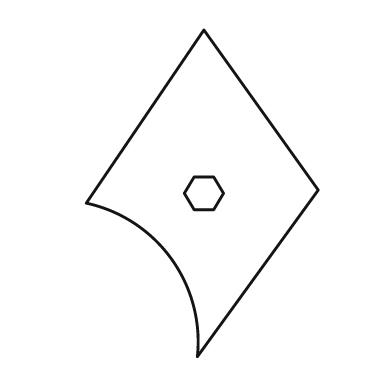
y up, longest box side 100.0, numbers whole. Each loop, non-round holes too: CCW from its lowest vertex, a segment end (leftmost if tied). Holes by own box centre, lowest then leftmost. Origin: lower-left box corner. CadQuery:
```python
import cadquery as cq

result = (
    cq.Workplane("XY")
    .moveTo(34.0, 0.0)
    .lineTo(71.0, 51.0)
    .lineTo(36.0, 100.0)
    .lineTo(0.0, 47.0)
    .threePointArc((26.0, 30.0), (34.0, 0.0))
    .close()
    .moveTo(33.0, 45.0)
    .lineTo(39.0, 45.0)
    .lineTo(42.0, 50.0)
    .lineTo(39.0, 55.0)
    .lineTo(33.0, 55.0)
    .lineTo(30.0, 50.0)
    .close()
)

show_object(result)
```